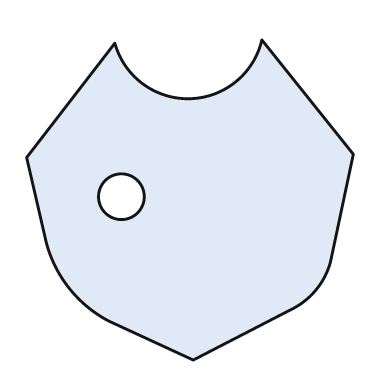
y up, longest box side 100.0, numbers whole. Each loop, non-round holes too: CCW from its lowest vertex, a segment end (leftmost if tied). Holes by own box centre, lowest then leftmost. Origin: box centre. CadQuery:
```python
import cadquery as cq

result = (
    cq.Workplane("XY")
    .moveTo(1.0, -49.0)
    .lineTo(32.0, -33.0)
    .threePointArc((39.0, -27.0), (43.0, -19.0))
    .lineTo(50.0, 14.0)
    .lineTo(22.0, 49.0)
    .threePointArc((0.0, 31.0), (-23.0, 48.0))
    .lineTo(-50.0, 13.0)
    .lineTo(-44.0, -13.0)
    .threePointArc((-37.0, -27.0), (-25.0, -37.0))
    .close()
    .moveTo(-21.0, 1.0)
    .circle(7.0)
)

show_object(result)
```